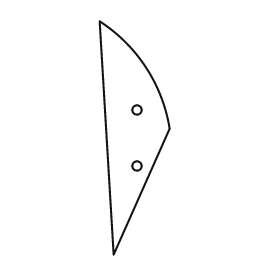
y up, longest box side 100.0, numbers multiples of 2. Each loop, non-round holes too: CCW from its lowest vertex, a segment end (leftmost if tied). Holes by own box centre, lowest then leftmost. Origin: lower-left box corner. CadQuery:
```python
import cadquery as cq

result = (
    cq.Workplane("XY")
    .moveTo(6.0, 0.0)
    .lineTo(30.0, 54.0)
    .threePointArc((20.0, 80.0), (0.0, 100.0))
    .close()
    .moveTo(16.0, 38.0)
    .circle(2.0)
    .moveTo(16.0, 62.0)
    .circle(2.0)
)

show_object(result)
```